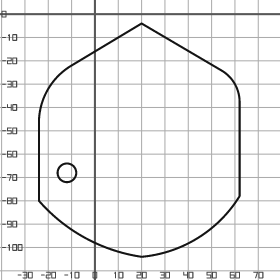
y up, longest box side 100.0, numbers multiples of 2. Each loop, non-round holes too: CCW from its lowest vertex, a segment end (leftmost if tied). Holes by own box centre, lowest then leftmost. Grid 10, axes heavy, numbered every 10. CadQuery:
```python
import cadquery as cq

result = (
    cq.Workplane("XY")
    .moveTo(20.0, -104.0)
    .threePointArc((44.0, -96.0), (62.0, -78.0))
    .lineTo(62.0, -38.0)
    .threePointArc((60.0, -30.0), (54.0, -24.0))
    .lineTo(20.0, -4.0)
    .lineTo(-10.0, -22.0)
    .threePointArc((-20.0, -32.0), (-24.0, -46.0))
    .lineTo(-24.0, -80.0)
    .threePointArc((-4.0, -96.0), (20.0, -104.0))
    .close()
    .moveTo(-12.0, -68.0)
    .circle(4.0)
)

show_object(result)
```